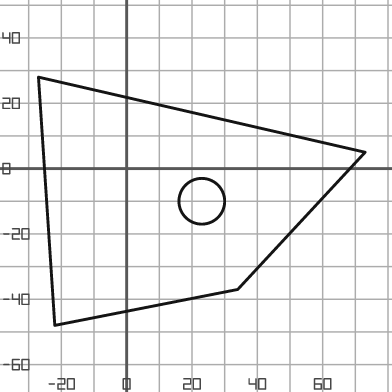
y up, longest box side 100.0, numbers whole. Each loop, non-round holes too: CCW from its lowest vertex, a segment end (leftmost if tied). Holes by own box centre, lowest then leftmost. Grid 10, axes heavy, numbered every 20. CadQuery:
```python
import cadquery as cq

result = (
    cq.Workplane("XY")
    .moveTo(-22.0, -48.0)
    .lineTo(34.0, -37.0)
    .lineTo(73.0, 5.0)
    .lineTo(-27.0, 28.0)
    .close()
    .moveTo(23.0, -10.0)
    .circle(7.0)
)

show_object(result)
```